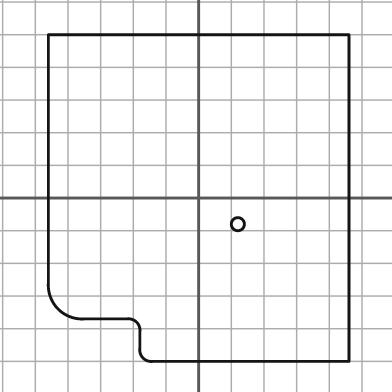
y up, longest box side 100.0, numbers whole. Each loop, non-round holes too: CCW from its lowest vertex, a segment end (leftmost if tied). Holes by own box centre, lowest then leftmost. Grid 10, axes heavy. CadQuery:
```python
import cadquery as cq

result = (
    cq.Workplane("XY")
    .moveTo(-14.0, -50.0)
    .lineTo(46.0, -50.0)
    .lineTo(46.0, 50.0)
    .lineTo(-46.0, 50.0)
    .lineTo(-46.0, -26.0)
    .threePointArc((-43.0, -34.0), (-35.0, -37.0))
    .lineTo(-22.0, -37.0)
    .threePointArc((-19.0, -38.0), (-18.0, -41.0))
    .lineTo(-18.0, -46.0)
    .threePointArc((-17.0, -49.0), (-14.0, -50.0))
    .close()
    .moveTo(12.0, -8.0)
    .circle(2.0)
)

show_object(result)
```